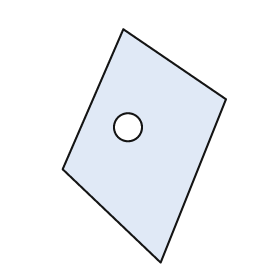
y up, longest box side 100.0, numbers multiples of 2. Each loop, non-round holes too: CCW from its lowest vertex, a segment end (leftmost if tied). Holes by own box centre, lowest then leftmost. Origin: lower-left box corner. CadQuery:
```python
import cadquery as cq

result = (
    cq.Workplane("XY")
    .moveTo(42.0, 0.0)
    .lineTo(70.0, 70.0)
    .lineTo(26.0, 100.0)
    .lineTo(0.0, 40.0)
    .close()
    .moveTo(28.0, 58.0)
    .circle(6.0)
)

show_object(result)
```